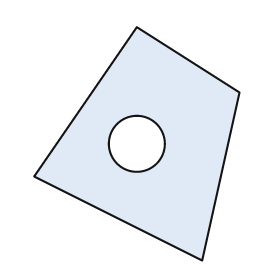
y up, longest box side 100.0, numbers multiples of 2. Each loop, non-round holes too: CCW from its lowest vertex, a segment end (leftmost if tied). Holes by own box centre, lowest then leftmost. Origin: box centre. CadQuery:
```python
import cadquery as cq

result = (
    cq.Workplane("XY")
    .moveTo(28.0, -50.0)
    .lineTo(44.0, 22.0)
    .lineTo(0.0, 50.0)
    .lineTo(-44.0, -14.0)
    .close()
    .moveTo(0.0, 0.0)
    .circle(12.0)
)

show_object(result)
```